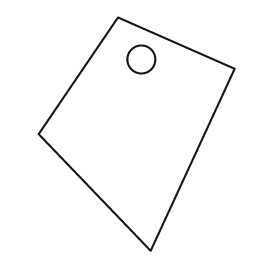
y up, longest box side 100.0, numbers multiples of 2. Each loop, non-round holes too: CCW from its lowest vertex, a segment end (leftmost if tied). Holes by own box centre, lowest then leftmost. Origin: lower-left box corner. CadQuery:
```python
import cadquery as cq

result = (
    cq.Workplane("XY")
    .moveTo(48.0, 0.0)
    .lineTo(84.0, 78.0)
    .lineTo(34.0, 100.0)
    .lineTo(0.0, 50.0)
    .close()
    .moveTo(44.0, 82.0)
    .circle(6.0)
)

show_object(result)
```